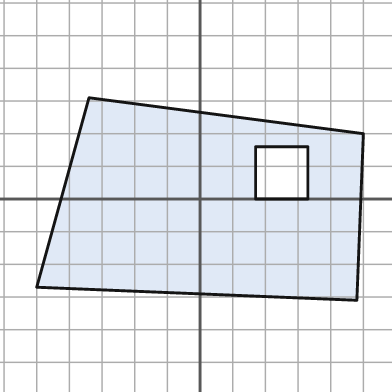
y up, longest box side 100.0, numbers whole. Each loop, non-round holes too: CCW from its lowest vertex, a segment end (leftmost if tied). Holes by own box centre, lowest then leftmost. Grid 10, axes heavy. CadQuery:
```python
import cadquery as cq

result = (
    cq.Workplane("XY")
    .moveTo(48.0, -31.0)
    .lineTo(50.0, 20.0)
    .lineTo(-34.0, 31.0)
    .lineTo(-50.0, -27.0)
    .close()
    .moveTo(17.0, 0.0)
    .lineTo(33.0, 0.0)
    .lineTo(33.0, 16.0)
    .lineTo(17.0, 16.0)
    .close()
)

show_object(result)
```